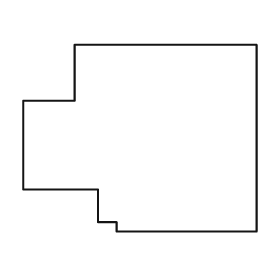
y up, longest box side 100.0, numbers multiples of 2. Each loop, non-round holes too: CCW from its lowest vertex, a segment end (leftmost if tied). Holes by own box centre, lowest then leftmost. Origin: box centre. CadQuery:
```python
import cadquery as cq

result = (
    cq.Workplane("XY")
    .moveTo(-10.0, -40.0)
    .lineTo(50.0, -40.0)
    .lineTo(50.0, 40.0)
    .lineTo(-28.0, 40.0)
    .lineTo(-28.0, 16.0)
    .lineTo(-50.0, 16.0)
    .lineTo(-50.0, -22.0)
    .lineTo(-18.0, -22.0)
    .lineTo(-18.0, -36.0)
    .lineTo(-10.0, -36.0)
    .close()
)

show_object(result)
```